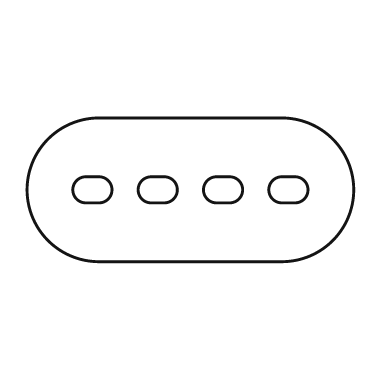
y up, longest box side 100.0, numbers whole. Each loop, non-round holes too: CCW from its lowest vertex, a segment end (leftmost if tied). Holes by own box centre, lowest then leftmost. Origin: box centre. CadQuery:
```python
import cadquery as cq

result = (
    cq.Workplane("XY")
    .moveTo(-28.0, -22.0)
    .lineTo(28.0, -22.0)
    .threePointArc((50.0, 0.0), (28.0, 22.0))
    .lineTo(-28.0, 22.0)
    .threePointArc((-50.0, 0.0), (-28.0, -22.0))
    .close()
    .moveTo(-32.0, -4.0)
    .lineTo(-28.0, -4.0)
    .threePointArc((-24.0, 0.0), (-28.0, 4.0))
    .lineTo(-32.0, 4.0)
    .threePointArc((-36.0, 0.0), (-32.0, -4.0))
    .close()
    .moveTo(-12.0, -4.0)
    .lineTo(-8.0, -4.0)
    .threePointArc((-4.0, 0.0), (-8.0, 4.0))
    .lineTo(-12.0, 4.0)
    .threePointArc((-16.0, 0.0), (-12.0, -4.0))
    .close()
    .moveTo(8.0, -4.0)
    .lineTo(12.0, -4.0)
    .threePointArc((16.0, 0.0), (12.0, 4.0))
    .lineTo(8.0, 4.0)
    .threePointArc((4.0, 0.0), (8.0, -4.0))
    .close()
    .moveTo(28.0, -4.0)
    .lineTo(32.0, -4.0)
    .threePointArc((36.0, 0.0), (32.0, 4.0))
    .lineTo(28.0, 4.0)
    .threePointArc((24.0, 0.0), (28.0, -4.0))
    .close()
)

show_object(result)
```